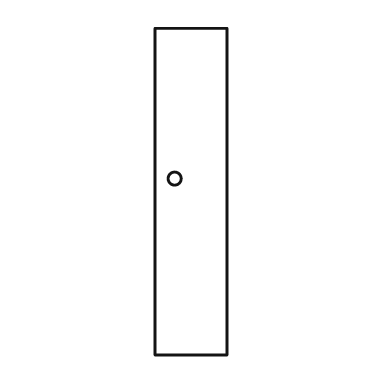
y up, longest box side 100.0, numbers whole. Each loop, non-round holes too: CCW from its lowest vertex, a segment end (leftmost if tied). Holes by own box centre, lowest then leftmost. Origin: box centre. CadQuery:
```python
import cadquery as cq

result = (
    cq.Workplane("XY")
    .moveTo(-11.0, -50.0)
    .lineTo(11.0, -50.0)
    .lineTo(11.0, 50.0)
    .lineTo(-11.0, 50.0)
    .close()
    .moveTo(-5.0, 4.0)
    .circle(2.0)
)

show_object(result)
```